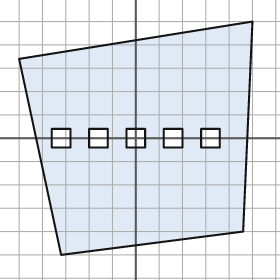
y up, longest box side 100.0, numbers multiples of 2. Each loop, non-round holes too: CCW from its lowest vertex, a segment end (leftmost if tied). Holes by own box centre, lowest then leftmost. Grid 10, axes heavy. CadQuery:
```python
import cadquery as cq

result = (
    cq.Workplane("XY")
    .moveTo(-32.0, -50.0)
    .lineTo(46.0, -40.0)
    .lineTo(50.0, 50.0)
    .lineTo(-50.0, 34.0)
    .close()
    .moveTo(-36.0, -4.0)
    .lineTo(-28.0, -4.0)
    .lineTo(-28.0, 4.0)
    .lineTo(-36.0, 4.0)
    .close()
    .moveTo(-20.0, -4.0)
    .lineTo(-12.0, -4.0)
    .lineTo(-12.0, 4.0)
    .lineTo(-20.0, 4.0)
    .close()
    .moveTo(-4.0, -4.0)
    .lineTo(4.0, -4.0)
    .lineTo(4.0, 4.0)
    .lineTo(-4.0, 4.0)
    .close()
    .moveTo(12.0, -4.0)
    .lineTo(20.0, -4.0)
    .lineTo(20.0, 4.0)
    .lineTo(12.0, 4.0)
    .close()
    .moveTo(28.0, -4.0)
    .lineTo(36.0, -4.0)
    .lineTo(36.0, 4.0)
    .lineTo(28.0, 4.0)
    .close()
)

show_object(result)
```